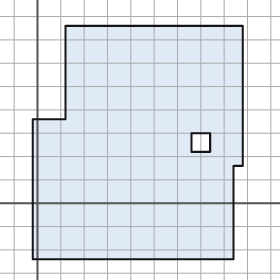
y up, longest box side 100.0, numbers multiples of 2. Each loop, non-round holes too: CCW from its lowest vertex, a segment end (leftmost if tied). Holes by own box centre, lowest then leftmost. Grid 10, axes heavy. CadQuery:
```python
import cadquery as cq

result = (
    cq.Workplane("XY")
    .moveTo(-2.0, -24.0)
    .lineTo(84.0, -24.0)
    .lineTo(84.0, 16.0)
    .lineTo(88.0, 16.0)
    .lineTo(88.0, 76.0)
    .lineTo(12.0, 76.0)
    .lineTo(12.0, 36.0)
    .lineTo(-2.0, 36.0)
    .close()
    .moveTo(66.0, 22.0)
    .lineTo(74.0, 22.0)
    .lineTo(74.0, 30.0)
    .lineTo(66.0, 30.0)
    .close()
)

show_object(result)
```